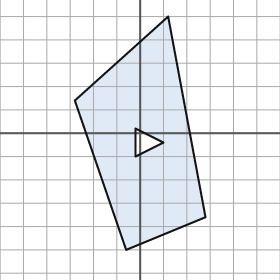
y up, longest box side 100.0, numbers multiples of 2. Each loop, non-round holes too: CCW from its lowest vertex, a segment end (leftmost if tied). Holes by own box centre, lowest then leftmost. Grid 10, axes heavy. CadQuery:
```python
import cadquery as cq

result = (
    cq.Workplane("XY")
    .moveTo(-6.0, -50.0)
    .lineTo(28.0, -36.0)
    .lineTo(12.0, 50.0)
    .lineTo(-28.0, 14.0)
    .close()
    .moveTo(-2.0, -10.0)
    .lineTo(10.0, -4.0)
    .lineTo(-2.0, 2.0)
    .close()
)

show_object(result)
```